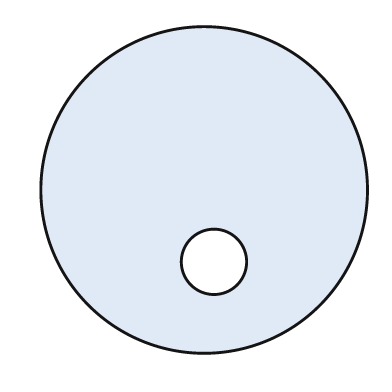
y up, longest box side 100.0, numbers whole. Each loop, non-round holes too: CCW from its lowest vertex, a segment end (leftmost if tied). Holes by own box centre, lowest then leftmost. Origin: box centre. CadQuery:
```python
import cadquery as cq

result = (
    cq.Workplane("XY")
    .moveTo(0.0, 0.0)
    .circle(50.0)
    .moveTo(3.0, -22.0)
    .circle(10.0)
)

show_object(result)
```